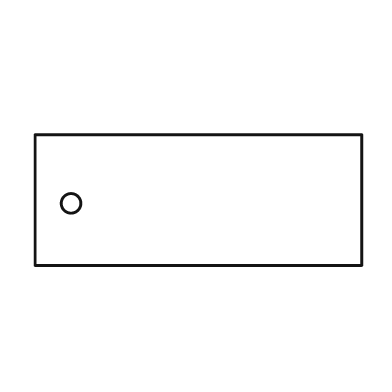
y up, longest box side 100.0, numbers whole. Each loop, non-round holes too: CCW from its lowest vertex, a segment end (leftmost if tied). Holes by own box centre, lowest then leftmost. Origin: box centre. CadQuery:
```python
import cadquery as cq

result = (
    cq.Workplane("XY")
    .moveTo(-50.0, -20.0)
    .lineTo(50.0, -20.0)
    .lineTo(50.0, 20.0)
    .lineTo(-50.0, 20.0)
    .close()
    .moveTo(-39.0, -1.0)
    .circle(3.0)
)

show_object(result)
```